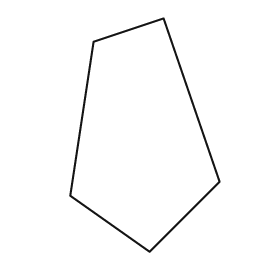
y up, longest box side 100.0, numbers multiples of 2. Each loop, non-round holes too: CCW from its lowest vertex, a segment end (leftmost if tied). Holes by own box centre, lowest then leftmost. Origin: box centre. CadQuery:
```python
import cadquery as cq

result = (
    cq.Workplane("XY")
    .moveTo(2.0, -50.0)
    .lineTo(32.0, -20.0)
    .lineTo(8.0, 50.0)
    .lineTo(-22.0, 40.0)
    .lineTo(-32.0, -26.0)
    .close()
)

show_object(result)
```